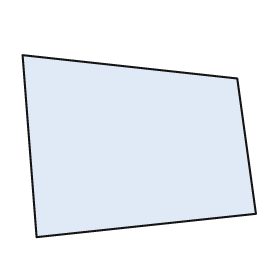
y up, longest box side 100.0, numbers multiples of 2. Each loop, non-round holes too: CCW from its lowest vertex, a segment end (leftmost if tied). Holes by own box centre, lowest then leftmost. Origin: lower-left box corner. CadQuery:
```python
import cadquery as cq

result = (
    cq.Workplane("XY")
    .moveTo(6.0, 0.0)
    .lineTo(100.0, 10.0)
    .lineTo(92.0, 68.0)
    .lineTo(0.0, 78.0)
    .close()
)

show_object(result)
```